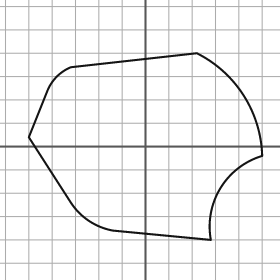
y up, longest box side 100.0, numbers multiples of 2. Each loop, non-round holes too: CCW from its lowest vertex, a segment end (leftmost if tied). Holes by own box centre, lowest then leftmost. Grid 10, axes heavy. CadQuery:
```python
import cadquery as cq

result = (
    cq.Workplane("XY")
    .moveTo(28.0, -40.0)
    .threePointArc((32.0, -18.0), (50.0, -4.0))
    .threePointArc((42.0, 22.0), (22.0, 40.0))
    .lineTo(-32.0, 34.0)
    .threePointArc((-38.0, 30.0), (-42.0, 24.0))
    .lineTo(-50.0, 4.0)
    .lineTo(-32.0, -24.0)
    .threePointArc((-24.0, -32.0), (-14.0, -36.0))
    .close()
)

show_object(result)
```